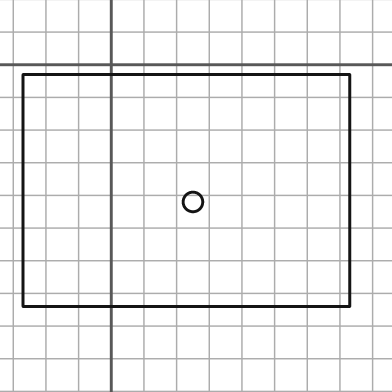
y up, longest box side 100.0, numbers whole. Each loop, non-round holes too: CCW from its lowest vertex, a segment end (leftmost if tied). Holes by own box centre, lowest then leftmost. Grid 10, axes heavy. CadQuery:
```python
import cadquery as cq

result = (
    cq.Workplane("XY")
    .moveTo(-27.0, -74.0)
    .lineTo(73.0, -74.0)
    .lineTo(73.0, -3.0)
    .lineTo(-27.0, -3.0)
    .close()
    .moveTo(25.0, -42.0)
    .circle(3.0)
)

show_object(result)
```